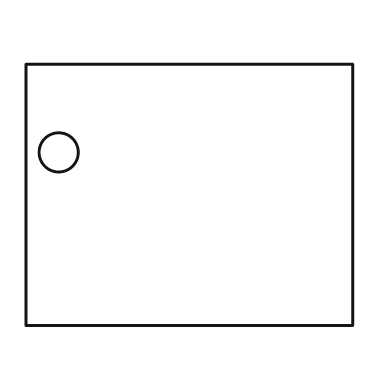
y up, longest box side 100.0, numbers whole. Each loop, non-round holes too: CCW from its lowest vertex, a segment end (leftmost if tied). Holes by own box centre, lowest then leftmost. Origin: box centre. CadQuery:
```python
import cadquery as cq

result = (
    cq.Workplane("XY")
    .moveTo(-50.0, -40.0)
    .lineTo(50.0, -40.0)
    .lineTo(50.0, 40.0)
    .lineTo(-50.0, 40.0)
    .close()
    .moveTo(-40.0, 13.0)
    .circle(6.0)
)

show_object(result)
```